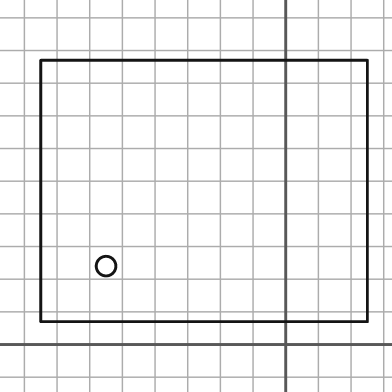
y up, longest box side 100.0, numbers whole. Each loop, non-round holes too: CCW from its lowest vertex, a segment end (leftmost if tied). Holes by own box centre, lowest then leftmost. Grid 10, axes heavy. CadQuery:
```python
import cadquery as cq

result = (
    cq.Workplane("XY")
    .moveTo(-75.0, 7.0)
    .lineTo(25.0, 7.0)
    .lineTo(25.0, 87.0)
    .lineTo(-75.0, 87.0)
    .close()
    .moveTo(-55.0, 24.0)
    .circle(3.0)
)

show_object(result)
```